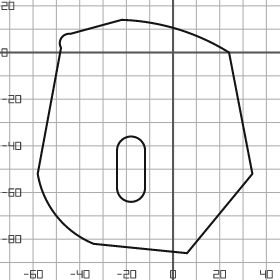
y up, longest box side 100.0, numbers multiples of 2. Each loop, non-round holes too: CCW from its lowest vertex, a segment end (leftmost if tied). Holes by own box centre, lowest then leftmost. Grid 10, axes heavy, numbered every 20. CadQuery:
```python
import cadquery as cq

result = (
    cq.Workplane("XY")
    .moveTo(6.0, -86.0)
    .lineTo(34.0, -52.0)
    .lineTo(24.0, 0.0)
    .threePointArc((2.0, 10.0), (-22.0, 14.0))
    .lineTo(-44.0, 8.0)
    .threePointArc((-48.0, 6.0), (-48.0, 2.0))
    .lineTo(-58.0, -52.0)
    .threePointArc((-50.0, -70.0), (-34.0, -82.0))
    .close()
    .moveTo(-24.0, -58.0)
    .threePointArc((-18.0, -64.0), (-12.0, -58.0))
    .lineTo(-12.0, -42.0)
    .threePointArc((-18.0, -36.0), (-24.0, -42.0))
    .close()
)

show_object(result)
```